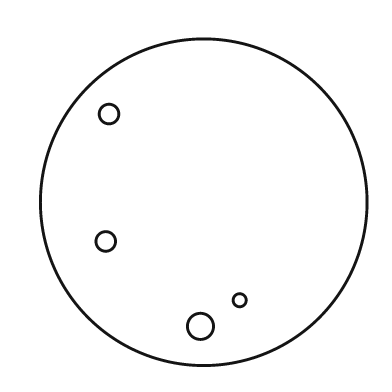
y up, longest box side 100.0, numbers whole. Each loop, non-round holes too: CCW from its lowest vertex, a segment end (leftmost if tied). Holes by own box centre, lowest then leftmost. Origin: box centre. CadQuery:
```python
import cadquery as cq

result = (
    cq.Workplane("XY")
    .moveTo(0.0, 0.0)
    .circle(50.0)
    .moveTo(-1.0, -38.0)
    .circle(4.0)
    .moveTo(11.0, -30.0)
    .circle(2.0)
    .moveTo(-30.0, -12.0)
    .circle(3.0)
    .moveTo(-29.0, 27.0)
    .circle(3.0)
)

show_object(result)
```